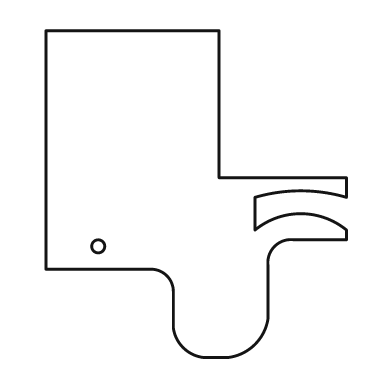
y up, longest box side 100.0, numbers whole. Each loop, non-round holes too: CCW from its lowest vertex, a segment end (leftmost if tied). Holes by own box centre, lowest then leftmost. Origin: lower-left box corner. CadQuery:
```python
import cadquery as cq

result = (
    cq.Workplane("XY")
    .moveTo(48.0, 0.0)
    .lineTo(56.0, 0.0)
    .threePointArc((64.0, 4.0), (68.0, 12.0))
    .lineTo(68.0, 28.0)
    .threePointArc((70.0, 34.0), (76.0, 36.0))
    .lineTo(92.0, 36.0)
    .lineTo(92.0, 39.0)
    .threePointArc((78.0, 44.0), (64.0, 39.0))
    .lineTo(64.0, 49.0)
    .threePointArc((78.0, 51.0), (92.0, 49.0))
    .lineTo(92.0, 55.0)
    .lineTo(53.0, 55.0)
    .lineTo(53.0, 100.0)
    .lineTo(0.0, 100.0)
    .lineTo(0.0, 27.0)
    .lineTo(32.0, 27.0)
    .threePointArc((37.0, 25.0), (39.0, 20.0))
    .lineTo(39.0, 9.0)
    .threePointArc((42.0, 3.0), (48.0, 0.0))
    .close()
    .moveTo(16.0, 34.0)
    .circle(2.0)
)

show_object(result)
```